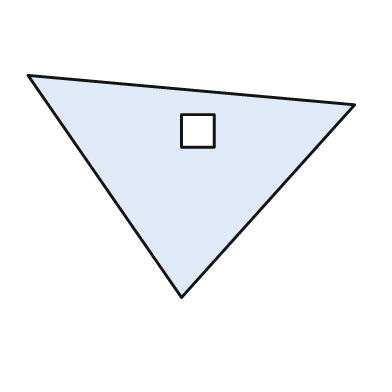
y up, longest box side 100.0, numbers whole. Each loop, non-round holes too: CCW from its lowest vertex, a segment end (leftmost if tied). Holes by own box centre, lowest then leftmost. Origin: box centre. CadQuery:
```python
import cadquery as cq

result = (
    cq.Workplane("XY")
    .moveTo(-3.0, -34.0)
    .lineTo(50.0, 25.0)
    .lineTo(-50.0, 34.0)
    .close()
    .moveTo(-3.0, 12.0)
    .lineTo(7.0, 12.0)
    .lineTo(7.0, 22.0)
    .lineTo(-3.0, 22.0)
    .close()
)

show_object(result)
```